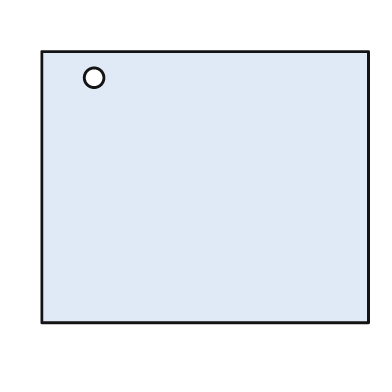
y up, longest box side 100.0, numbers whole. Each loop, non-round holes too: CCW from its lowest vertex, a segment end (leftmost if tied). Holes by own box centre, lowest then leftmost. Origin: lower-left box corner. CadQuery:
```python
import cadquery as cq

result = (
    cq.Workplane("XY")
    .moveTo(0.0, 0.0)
    .lineTo(100.0, 0.0)
    .lineTo(100.0, 83.0)
    .lineTo(0.0, 83.0)
    .close()
    .moveTo(16.0, 75.0)
    .circle(3.0)
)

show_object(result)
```